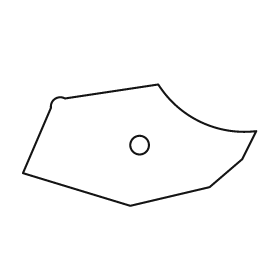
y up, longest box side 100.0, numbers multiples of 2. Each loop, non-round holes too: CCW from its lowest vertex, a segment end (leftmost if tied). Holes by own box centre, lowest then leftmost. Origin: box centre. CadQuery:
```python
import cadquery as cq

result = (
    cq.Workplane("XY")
    .moveTo(-4.0, -26.0)
    .lineTo(30.0, -18.0)
    .lineTo(44.0, -6.0)
    .lineTo(50.0, 6.0)
    .threePointArc((26.0, 10.0), (8.0, 26.0))
    .lineTo(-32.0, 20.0)
    .threePointArc((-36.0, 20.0), (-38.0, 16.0))
    .lineTo(-50.0, -12.0)
    .close()
    .moveTo(0.0, 0.0)
    .circle(4.0)
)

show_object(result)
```